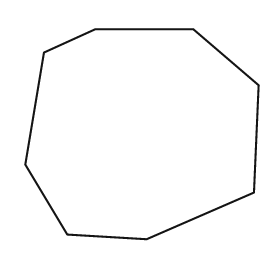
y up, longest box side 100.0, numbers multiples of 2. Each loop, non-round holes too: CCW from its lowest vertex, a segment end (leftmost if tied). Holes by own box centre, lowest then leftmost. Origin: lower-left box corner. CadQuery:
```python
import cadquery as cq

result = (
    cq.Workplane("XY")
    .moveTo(52.0, 0.0)
    .lineTo(98.0, 20.0)
    .lineTo(100.0, 66.0)
    .lineTo(72.0, 90.0)
    .lineTo(30.0, 90.0)
    .lineTo(8.0, 80.0)
    .lineTo(0.0, 32.0)
    .lineTo(18.0, 2.0)
    .close()
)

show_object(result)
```